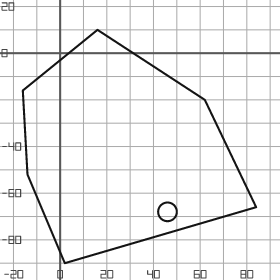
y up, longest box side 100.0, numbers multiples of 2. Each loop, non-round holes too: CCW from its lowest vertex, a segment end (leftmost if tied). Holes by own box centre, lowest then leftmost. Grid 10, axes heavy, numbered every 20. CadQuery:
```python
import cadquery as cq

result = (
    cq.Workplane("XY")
    .moveTo(2.0, -90.0)
    .lineTo(84.0, -66.0)
    .lineTo(62.0, -20.0)
    .lineTo(16.0, 10.0)
    .lineTo(-16.0, -16.0)
    .lineTo(-14.0, -52.0)
    .close()
    .moveTo(46.0, -68.0)
    .circle(4.0)
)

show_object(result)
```